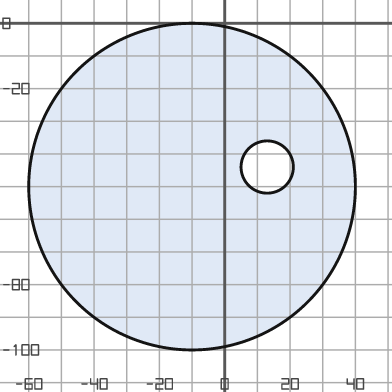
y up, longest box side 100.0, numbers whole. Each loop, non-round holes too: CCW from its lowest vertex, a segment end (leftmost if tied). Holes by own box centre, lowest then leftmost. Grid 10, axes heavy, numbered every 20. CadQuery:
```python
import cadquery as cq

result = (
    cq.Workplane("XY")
    .moveTo(-10.0, -50.0)
    .circle(50.0)
    .moveTo(13.0, -44.0)
    .circle(8.0)
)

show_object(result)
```